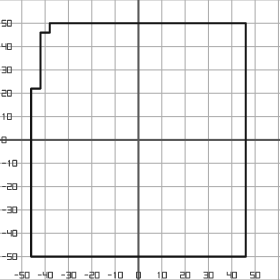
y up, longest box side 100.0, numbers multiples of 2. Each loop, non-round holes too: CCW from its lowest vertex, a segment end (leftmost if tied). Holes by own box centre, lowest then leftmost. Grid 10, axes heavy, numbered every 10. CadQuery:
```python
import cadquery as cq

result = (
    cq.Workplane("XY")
    .moveTo(-46.0, -50.0)
    .lineTo(46.0, -50.0)
    .lineTo(46.0, 50.0)
    .lineTo(-38.0, 50.0)
    .lineTo(-38.0, 46.0)
    .lineTo(-42.0, 46.0)
    .lineTo(-42.0, 22.0)
    .lineTo(-46.0, 22.0)
    .close()
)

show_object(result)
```